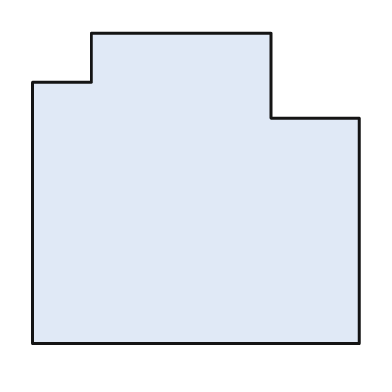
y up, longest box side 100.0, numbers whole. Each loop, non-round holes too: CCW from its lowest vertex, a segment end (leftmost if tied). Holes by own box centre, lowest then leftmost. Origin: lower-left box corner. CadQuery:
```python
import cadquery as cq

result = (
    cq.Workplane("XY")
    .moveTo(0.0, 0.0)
    .lineTo(100.0, 0.0)
    .lineTo(100.0, 69.0)
    .lineTo(73.0, 69.0)
    .lineTo(73.0, 95.0)
    .lineTo(18.0, 95.0)
    .lineTo(18.0, 80.0)
    .lineTo(0.0, 80.0)
    .close()
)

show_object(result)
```